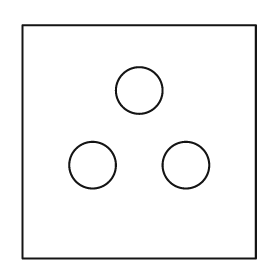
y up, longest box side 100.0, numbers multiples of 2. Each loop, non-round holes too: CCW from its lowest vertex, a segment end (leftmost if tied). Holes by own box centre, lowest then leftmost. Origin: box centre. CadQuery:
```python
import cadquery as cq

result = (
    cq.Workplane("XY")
    .moveTo(-50.0, -50.0)
    .lineTo(50.0, -50.0)
    .lineTo(50.0, 50.0)
    .lineTo(-50.0, 50.0)
    .close()
    .moveTo(-20.0, -10.0)
    .circle(10.0)
    .moveTo(20.0, -10.0)
    .circle(10.0)
    .moveTo(0.0, 22.0)
    .circle(10.0)
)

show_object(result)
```